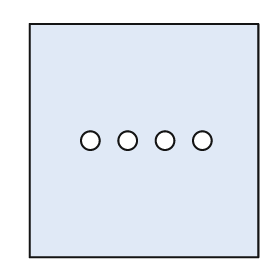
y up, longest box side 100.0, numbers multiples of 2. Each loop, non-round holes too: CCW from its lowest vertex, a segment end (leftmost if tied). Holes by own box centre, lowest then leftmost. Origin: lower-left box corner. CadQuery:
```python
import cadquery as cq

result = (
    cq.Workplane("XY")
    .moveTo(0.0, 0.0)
    .lineTo(98.0, 0.0)
    .lineTo(98.0, 100.0)
    .lineTo(0.0, 100.0)
    .close()
    .moveTo(26.0, 50.0)
    .circle(4.0)
    .moveTo(42.0, 50.0)
    .circle(4.0)
    .moveTo(58.0, 50.0)
    .circle(4.0)
    .moveTo(74.0, 50.0)
    .circle(4.0)
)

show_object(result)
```